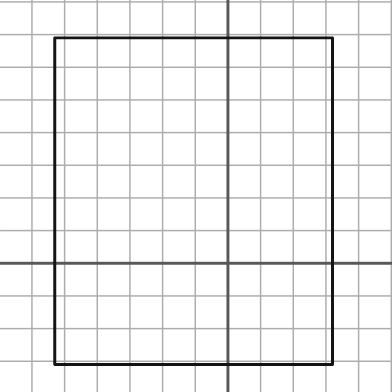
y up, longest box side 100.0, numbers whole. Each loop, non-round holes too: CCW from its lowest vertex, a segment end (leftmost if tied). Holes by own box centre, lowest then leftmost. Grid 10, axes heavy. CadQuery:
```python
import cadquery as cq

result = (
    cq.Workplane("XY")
    .moveTo(-53.0, -31.0)
    .lineTo(32.0, -31.0)
    .lineTo(32.0, 69.0)
    .lineTo(-53.0, 69.0)
    .close()
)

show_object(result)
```